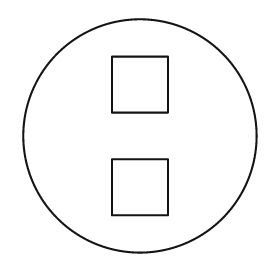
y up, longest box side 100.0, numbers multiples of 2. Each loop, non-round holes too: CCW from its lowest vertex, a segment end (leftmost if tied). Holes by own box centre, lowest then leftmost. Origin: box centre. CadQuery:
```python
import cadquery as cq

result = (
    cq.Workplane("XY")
    .moveTo(0.0, 0.0)
    .circle(50.0)
    .moveTo(-12.0, -34.0)
    .lineTo(12.0, -34.0)
    .lineTo(12.0, -10.0)
    .lineTo(-12.0, -10.0)
    .close()
    .moveTo(-12.0, 10.0)
    .lineTo(12.0, 10.0)
    .lineTo(12.0, 34.0)
    .lineTo(-12.0, 34.0)
    .close()
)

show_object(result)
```